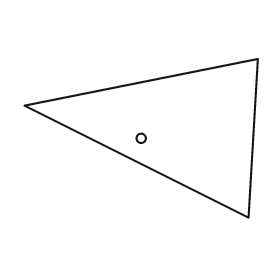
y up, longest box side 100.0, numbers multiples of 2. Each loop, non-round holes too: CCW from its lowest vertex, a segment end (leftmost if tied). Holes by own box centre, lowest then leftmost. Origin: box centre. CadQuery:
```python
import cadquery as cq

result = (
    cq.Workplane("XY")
    .moveTo(46.0, -34.0)
    .lineTo(50.0, 34.0)
    .lineTo(-50.0, 14.0)
    .close()
    .moveTo(0.0, 0.0)
    .circle(2.0)
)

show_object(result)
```